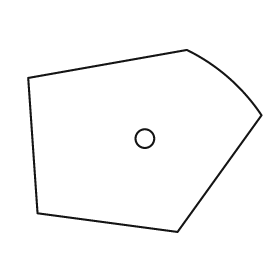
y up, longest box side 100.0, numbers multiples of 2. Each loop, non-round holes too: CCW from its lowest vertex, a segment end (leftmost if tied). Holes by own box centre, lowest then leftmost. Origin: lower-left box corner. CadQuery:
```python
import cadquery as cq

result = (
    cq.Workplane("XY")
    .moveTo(64.0, 0.0)
    .lineTo(100.0, 50.0)
    .threePointArc((86.0, 66.0), (68.0, 78.0))
    .lineTo(0.0, 66.0)
    .lineTo(4.0, 8.0)
    .close()
    .moveTo(50.0, 40.0)
    .circle(4.0)
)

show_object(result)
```